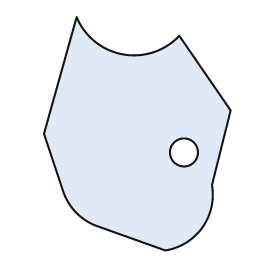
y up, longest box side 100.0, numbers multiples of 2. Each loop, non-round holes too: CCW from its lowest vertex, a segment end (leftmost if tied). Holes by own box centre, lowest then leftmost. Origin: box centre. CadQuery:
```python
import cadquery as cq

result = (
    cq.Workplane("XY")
    .moveTo(12.0, -50.0)
    .threePointArc((28.0, -40.0), (32.0, -22.0))
    .lineTo(40.0, 10.0)
    .lineTo(18.0, 42.0)
    .threePointArc((-6.0, 34.0), (-26.0, 50.0))
    .lineTo(-40.0, 0.0)
    .lineTo(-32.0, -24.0)
    .threePointArc((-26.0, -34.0), (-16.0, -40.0))
    .close()
    .moveTo(20.0, -8.0)
    .circle(6.0)
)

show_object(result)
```